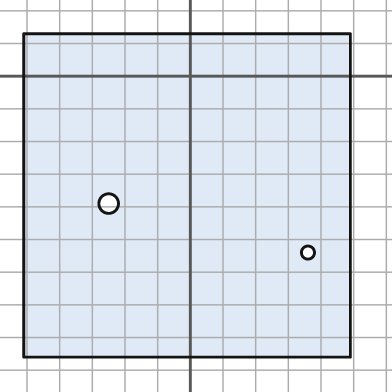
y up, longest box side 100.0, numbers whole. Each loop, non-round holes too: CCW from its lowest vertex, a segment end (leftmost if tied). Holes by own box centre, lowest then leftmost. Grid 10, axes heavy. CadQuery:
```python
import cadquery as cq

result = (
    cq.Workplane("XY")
    .moveTo(-51.0, -86.0)
    .lineTo(49.0, -86.0)
    .lineTo(49.0, 13.0)
    .lineTo(-51.0, 13.0)
    .close()
    .moveTo(36.0, -54.0)
    .circle(2.0)
    .moveTo(-25.0, -39.0)
    .circle(3.0)
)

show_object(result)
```